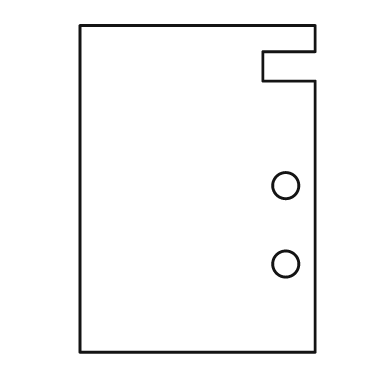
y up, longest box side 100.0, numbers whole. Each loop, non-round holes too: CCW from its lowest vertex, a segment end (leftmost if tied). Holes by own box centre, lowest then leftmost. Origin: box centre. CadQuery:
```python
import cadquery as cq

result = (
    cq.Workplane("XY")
    .moveTo(-36.0, -50.0)
    .lineTo(36.0, -50.0)
    .lineTo(36.0, 33.0)
    .lineTo(20.0, 33.0)
    .lineTo(20.0, 42.0)
    .lineTo(36.0, 42.0)
    .lineTo(36.0, 50.0)
    .lineTo(-36.0, 50.0)
    .close()
    .moveTo(27.0, -23.0)
    .circle(4.0)
    .moveTo(27.0, 1.0)
    .circle(4.0)
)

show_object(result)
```